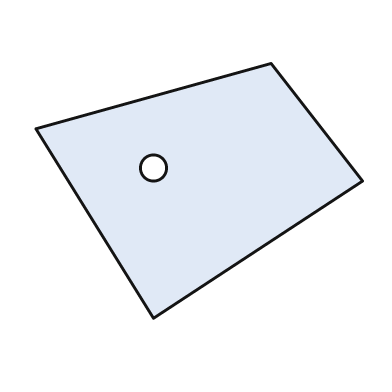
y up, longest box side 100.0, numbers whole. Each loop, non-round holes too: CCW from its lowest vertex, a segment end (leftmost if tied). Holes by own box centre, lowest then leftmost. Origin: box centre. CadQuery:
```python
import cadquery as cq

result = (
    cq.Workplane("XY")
    .moveTo(-14.0, -39.0)
    .lineTo(50.0, 3.0)
    .lineTo(22.0, 39.0)
    .lineTo(-50.0, 19.0)
    .close()
    .moveTo(-14.0, 7.0)
    .circle(4.0)
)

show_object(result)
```